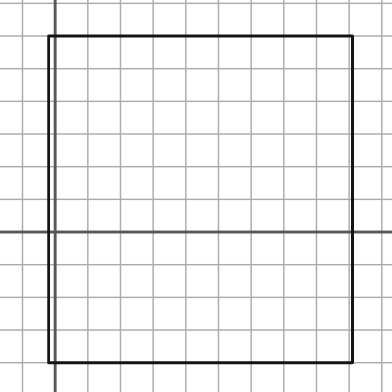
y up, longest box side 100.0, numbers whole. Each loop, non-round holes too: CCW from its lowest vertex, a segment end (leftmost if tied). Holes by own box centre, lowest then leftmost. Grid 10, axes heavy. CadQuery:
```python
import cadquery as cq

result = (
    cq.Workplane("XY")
    .moveTo(-2.0, -40.0)
    .lineTo(91.0, -40.0)
    .lineTo(91.0, 60.0)
    .lineTo(-2.0, 60.0)
    .close()
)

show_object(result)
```